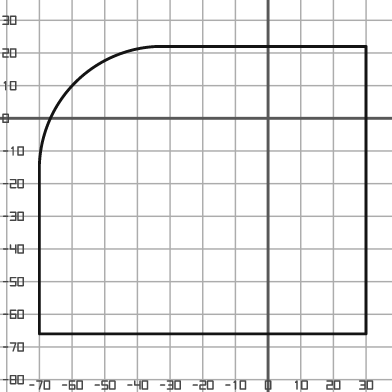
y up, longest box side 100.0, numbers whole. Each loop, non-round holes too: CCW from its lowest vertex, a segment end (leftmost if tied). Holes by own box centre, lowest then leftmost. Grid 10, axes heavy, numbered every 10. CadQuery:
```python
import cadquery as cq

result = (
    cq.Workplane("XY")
    .moveTo(-70.0, -66.0)
    .lineTo(30.0, -66.0)
    .lineTo(30.0, 22.0)
    .lineTo(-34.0, 22.0)
    .threePointArc((-59.0, 11.0), (-70.0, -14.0))
    .close()
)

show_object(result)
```